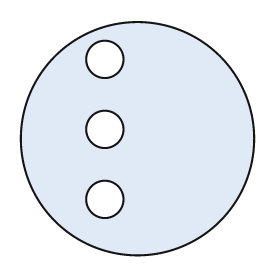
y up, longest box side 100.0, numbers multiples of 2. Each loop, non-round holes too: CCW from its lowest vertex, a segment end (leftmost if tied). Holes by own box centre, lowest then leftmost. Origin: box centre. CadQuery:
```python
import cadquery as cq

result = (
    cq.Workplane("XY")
    .moveTo(0.0, 0.0)
    .circle(50.0)
    .moveTo(-14.0, -26.0)
    .circle(8.0)
    .moveTo(-14.0, 4.0)
    .circle(8.0)
    .moveTo(-14.0, 34.0)
    .circle(8.0)
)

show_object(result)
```